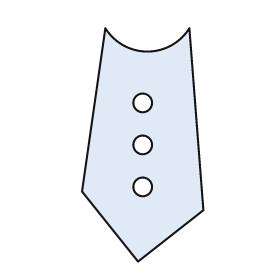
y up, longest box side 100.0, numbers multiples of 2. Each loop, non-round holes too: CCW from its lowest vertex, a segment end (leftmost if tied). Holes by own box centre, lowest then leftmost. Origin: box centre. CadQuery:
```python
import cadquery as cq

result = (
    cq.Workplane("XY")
    .moveTo(-2.0, -50.0)
    .lineTo(26.0, -28.0)
    .lineTo(20.0, 50.0)
    .threePointArc((2.0, 40.0), (-16.0, 50.0))
    .lineTo(-26.0, -20.0)
    .close()
    .moveTo(0.0, -18.0)
    .circle(4.0)
    .moveTo(0.0, 0.0)
    .circle(4.0)
    .moveTo(0.0, 18.0)
    .circle(4.0)
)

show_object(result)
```